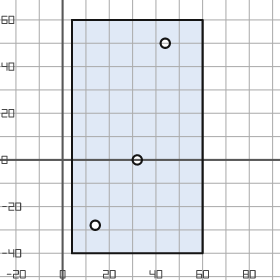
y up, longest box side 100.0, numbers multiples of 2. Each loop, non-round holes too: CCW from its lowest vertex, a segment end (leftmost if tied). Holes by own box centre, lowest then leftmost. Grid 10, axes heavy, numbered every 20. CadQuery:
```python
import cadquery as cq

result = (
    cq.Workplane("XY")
    .moveTo(4.0, -40.0)
    .lineTo(60.0, -40.0)
    .lineTo(60.0, 60.0)
    .lineTo(4.0, 60.0)
    .close()
    .moveTo(14.0, -28.0)
    .circle(2.0)
    .moveTo(32.0, 0.0)
    .circle(2.0)
    .moveTo(44.0, 50.0)
    .circle(2.0)
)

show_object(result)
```